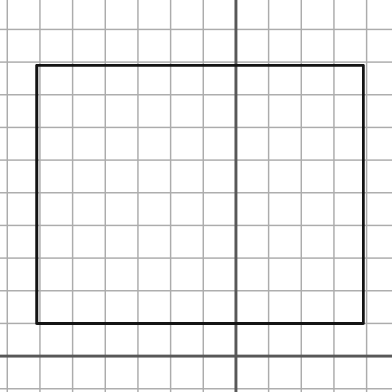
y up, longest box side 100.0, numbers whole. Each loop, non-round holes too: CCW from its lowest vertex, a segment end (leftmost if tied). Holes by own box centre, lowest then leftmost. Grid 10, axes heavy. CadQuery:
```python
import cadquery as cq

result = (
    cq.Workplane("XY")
    .moveTo(-61.0, 10.0)
    .lineTo(39.0, 10.0)
    .lineTo(39.0, 89.0)
    .lineTo(-61.0, 89.0)
    .close()
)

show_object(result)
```